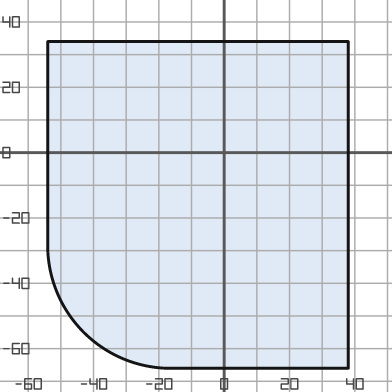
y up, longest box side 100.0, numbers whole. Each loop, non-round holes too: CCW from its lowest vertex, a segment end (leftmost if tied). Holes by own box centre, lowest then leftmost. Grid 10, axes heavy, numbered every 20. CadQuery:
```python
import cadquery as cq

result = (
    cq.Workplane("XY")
    .moveTo(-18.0, -66.0)
    .lineTo(38.0, -66.0)
    .lineTo(38.0, 34.0)
    .lineTo(-54.0, 34.0)
    .lineTo(-54.0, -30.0)
    .threePointArc((-43.0, -55.0), (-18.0, -66.0))
    .close()
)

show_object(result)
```